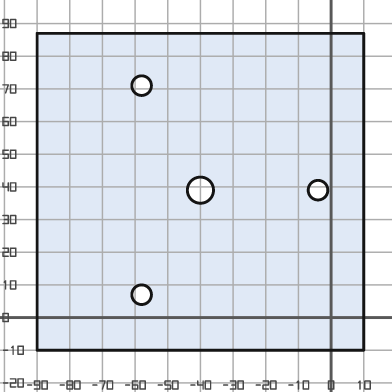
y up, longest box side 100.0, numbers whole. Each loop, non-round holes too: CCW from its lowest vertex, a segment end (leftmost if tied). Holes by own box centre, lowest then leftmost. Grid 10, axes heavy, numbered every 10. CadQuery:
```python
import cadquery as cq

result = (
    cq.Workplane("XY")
    .moveTo(-90.0, -10.0)
    .lineTo(10.0, -10.0)
    .lineTo(10.0, 87.0)
    .lineTo(-90.0, 87.0)
    .close()
    .moveTo(-58.0, 7.0)
    .circle(3.0)
    .moveTo(-40.0, 39.0)
    .circle(4.0)
    .moveTo(-4.0, 39.0)
    .circle(3.0)
    .moveTo(-58.0, 71.0)
    .circle(3.0)
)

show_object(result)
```